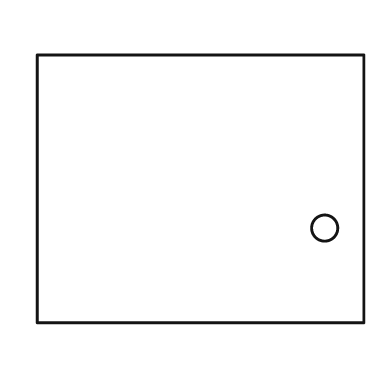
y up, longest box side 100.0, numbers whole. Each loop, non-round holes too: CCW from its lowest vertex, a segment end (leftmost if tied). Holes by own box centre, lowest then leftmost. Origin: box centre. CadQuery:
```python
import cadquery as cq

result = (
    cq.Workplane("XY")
    .moveTo(-50.0, -41.0)
    .lineTo(50.0, -41.0)
    .lineTo(50.0, 41.0)
    .lineTo(-50.0, 41.0)
    .close()
    .moveTo(38.0, -12.0)
    .circle(4.0)
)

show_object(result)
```